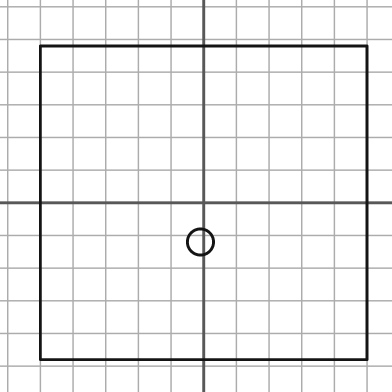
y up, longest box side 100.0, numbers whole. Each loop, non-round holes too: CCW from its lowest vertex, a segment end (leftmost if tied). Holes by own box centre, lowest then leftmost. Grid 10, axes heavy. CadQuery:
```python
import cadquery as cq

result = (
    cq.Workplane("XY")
    .moveTo(-50.0, -48.0)
    .lineTo(50.0, -48.0)
    .lineTo(50.0, 48.0)
    .lineTo(-50.0, 48.0)
    .close()
    .moveTo(-1.0, -12.0)
    .circle(4.0)
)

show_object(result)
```